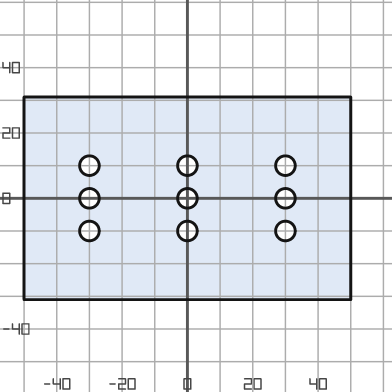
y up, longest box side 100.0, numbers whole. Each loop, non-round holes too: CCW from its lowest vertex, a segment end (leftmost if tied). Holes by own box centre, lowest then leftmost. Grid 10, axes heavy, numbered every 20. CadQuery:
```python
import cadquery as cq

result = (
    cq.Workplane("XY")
    .moveTo(-50.0, -31.0)
    .lineTo(50.0, -31.0)
    .lineTo(50.0, 31.0)
    .lineTo(-50.0, 31.0)
    .close()
    .moveTo(-30.0, -10.0)
    .circle(3.0)
    .moveTo(0.0, -10.0)
    .circle(3.0)
    .moveTo(30.0, -10.0)
    .circle(3.0)
    .moveTo(-30.0, 0.0)
    .circle(3.0)
    .moveTo(0.0, 0.0)
    .circle(3.0)
    .moveTo(30.0, 0.0)
    .circle(3.0)
    .moveTo(-30.0, 10.0)
    .circle(3.0)
    .moveTo(0.0, 10.0)
    .circle(3.0)
    .moveTo(30.0, 10.0)
    .circle(3.0)
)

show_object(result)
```